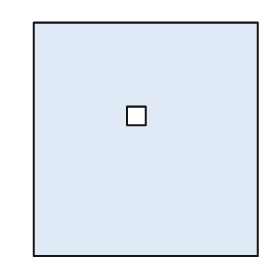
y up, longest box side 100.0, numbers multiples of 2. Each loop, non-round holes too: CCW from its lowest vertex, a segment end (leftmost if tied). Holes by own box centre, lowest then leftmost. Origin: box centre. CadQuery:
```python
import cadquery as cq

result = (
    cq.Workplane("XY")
    .moveTo(-48.0, -50.0)
    .lineTo(48.0, -50.0)
    .lineTo(48.0, 50.0)
    .lineTo(-48.0, 50.0)
    .close()
    .moveTo(-8.0, 6.0)
    .lineTo(0.0, 6.0)
    .lineTo(0.0, 14.0)
    .lineTo(-8.0, 14.0)
    .close()
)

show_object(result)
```